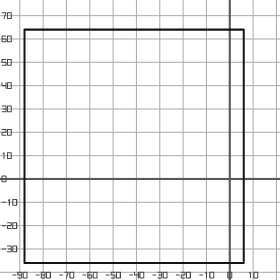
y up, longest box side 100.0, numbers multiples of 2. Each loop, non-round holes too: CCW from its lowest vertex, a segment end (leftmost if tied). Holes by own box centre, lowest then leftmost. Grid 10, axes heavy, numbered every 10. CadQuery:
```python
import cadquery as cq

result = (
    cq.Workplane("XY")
    .moveTo(-88.0, -36.0)
    .lineTo(6.0, -36.0)
    .lineTo(6.0, 64.0)
    .lineTo(-88.0, 64.0)
    .close()
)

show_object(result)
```